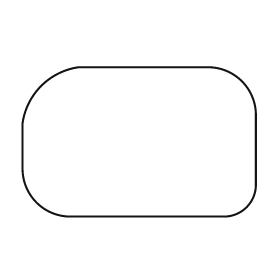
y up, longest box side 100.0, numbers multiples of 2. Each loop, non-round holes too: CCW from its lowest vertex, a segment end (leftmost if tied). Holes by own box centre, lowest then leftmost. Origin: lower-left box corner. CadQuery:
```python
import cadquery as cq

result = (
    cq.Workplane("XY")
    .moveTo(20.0, 0.0)
    .lineTo(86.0, 0.0)
    .threePointArc((96.0, 4.0), (100.0, 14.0))
    .lineTo(100.0, 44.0)
    .threePointArc((94.0, 58.0), (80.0, 64.0))
    .lineTo(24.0, 64.0)
    .threePointArc((8.0, 56.0), (0.0, 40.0))
    .lineTo(0.0, 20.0)
    .threePointArc((6.0, 6.0), (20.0, 0.0))
    .close()
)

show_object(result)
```